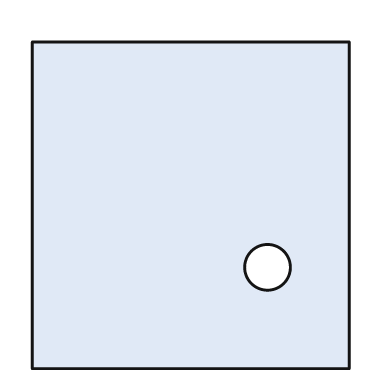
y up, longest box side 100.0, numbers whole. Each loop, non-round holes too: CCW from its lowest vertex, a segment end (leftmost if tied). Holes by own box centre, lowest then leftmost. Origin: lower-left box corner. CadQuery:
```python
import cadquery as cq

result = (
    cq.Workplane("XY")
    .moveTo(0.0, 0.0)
    .lineTo(97.0, 0.0)
    .lineTo(97.0, 100.0)
    .lineTo(0.0, 100.0)
    .close()
    .moveTo(72.0, 31.0)
    .circle(7.0)
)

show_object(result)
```